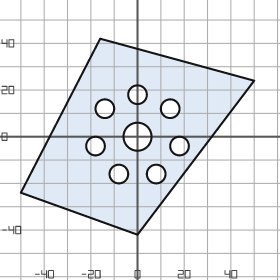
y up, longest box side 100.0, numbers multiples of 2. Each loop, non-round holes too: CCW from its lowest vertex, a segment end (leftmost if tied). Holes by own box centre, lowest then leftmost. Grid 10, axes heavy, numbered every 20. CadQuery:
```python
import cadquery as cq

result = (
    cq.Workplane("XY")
    .moveTo(0.0, -42.0)
    .lineTo(50.0, 24.0)
    .lineTo(-16.0, 42.0)
    .lineTo(-50.0, -24.0)
    .close()
    .moveTo(-8.0, -16.0)
    .circle(4.0)
    .moveTo(8.0, -16.0)
    .circle(4.0)
    .moveTo(-18.0, -4.0)
    .circle(4.0)
    .moveTo(18.0, -4.0)
    .circle(4.0)
    .moveTo(0.0, 0.0)
    .circle(6.0)
    .moveTo(-14.0, 12.0)
    .circle(4.0)
    .moveTo(14.0, 12.0)
    .circle(4.0)
    .moveTo(0.0, 18.0)
    .circle(4.0)
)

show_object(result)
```